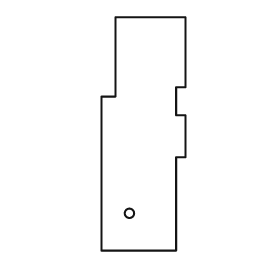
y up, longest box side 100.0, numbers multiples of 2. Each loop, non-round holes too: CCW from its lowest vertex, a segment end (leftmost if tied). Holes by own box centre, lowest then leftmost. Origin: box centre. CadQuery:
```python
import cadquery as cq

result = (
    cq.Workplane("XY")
    .moveTo(-18.0, -50.0)
    .lineTo(14.0, -50.0)
    .lineTo(14.0, -10.0)
    .lineTo(18.0, -10.0)
    .lineTo(18.0, 8.0)
    .lineTo(14.0, 8.0)
    .lineTo(14.0, 20.0)
    .lineTo(18.0, 20.0)
    .lineTo(18.0, 50.0)
    .lineTo(-12.0, 50.0)
    .lineTo(-12.0, 16.0)
    .lineTo(-18.0, 16.0)
    .close()
    .moveTo(-6.0, -34.0)
    .circle(2.0)
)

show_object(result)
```